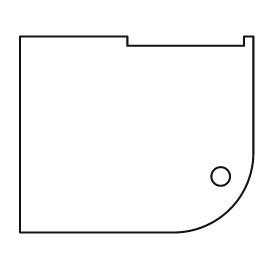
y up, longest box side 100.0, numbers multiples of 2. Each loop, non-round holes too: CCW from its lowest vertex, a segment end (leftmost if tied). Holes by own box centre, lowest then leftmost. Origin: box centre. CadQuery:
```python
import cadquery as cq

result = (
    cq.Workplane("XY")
    .moveTo(-50.0, -42.0)
    .lineTo(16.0, -42.0)
    .threePointArc((40.0, -32.0), (50.0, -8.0))
    .lineTo(50.0, 42.0)
    .lineTo(46.0, 42.0)
    .lineTo(46.0, 38.0)
    .lineTo(-4.0, 38.0)
    .lineTo(-4.0, 42.0)
    .lineTo(-50.0, 42.0)
    .close()
    .moveTo(36.0, -18.0)
    .circle(4.0)
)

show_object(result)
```